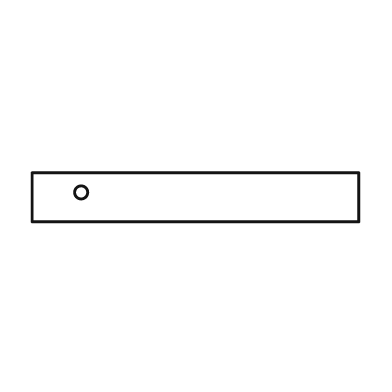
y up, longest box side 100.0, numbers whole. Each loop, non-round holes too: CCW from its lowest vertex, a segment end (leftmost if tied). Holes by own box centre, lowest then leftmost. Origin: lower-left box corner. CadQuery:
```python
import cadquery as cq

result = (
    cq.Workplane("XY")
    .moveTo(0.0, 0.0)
    .lineTo(100.0, 0.0)
    .lineTo(100.0, 15.0)
    .lineTo(0.0, 15.0)
    .close()
    .moveTo(15.0, 9.0)
    .circle(2.0)
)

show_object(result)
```